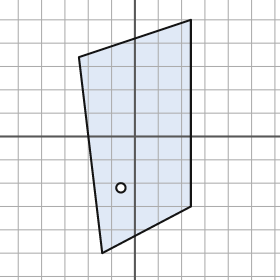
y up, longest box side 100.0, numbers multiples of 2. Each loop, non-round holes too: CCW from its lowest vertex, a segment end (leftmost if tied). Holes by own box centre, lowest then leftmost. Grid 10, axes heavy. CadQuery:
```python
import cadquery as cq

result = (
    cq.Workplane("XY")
    .moveTo(-14.0, -50.0)
    .lineTo(24.0, -30.0)
    .lineTo(24.0, 50.0)
    .lineTo(-24.0, 34.0)
    .close()
    .moveTo(-6.0, -22.0)
    .circle(2.0)
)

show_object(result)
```